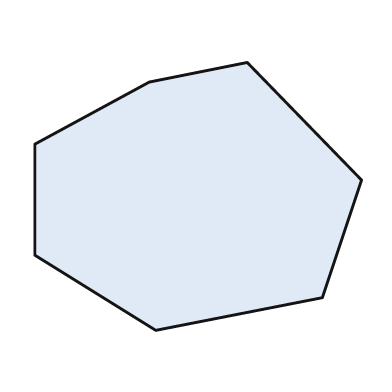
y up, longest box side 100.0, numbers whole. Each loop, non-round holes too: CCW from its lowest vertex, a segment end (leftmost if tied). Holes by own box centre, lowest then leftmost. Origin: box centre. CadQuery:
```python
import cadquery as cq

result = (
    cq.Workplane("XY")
    .moveTo(-13.0, -41.0)
    .lineTo(38.0, -31.0)
    .lineTo(50.0, 5.0)
    .lineTo(15.0, 41.0)
    .lineTo(-15.0, 35.0)
    .lineTo(-50.0, 16.0)
    .lineTo(-50.0, -18.0)
    .close()
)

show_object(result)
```